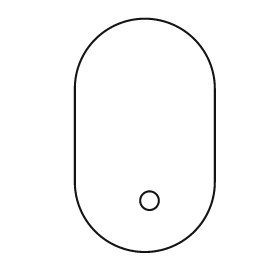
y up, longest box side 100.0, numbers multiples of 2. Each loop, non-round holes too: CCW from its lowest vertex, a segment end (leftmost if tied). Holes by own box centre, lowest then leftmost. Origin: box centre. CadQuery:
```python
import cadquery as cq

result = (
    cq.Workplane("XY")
    .moveTo(-30.0, -20.0)
    .threePointArc((0.0, -50.0), (30.0, -20.0))
    .lineTo(30.0, 20.0)
    .threePointArc((0.0, 50.0), (-30.0, 20.0))
    .close()
    .moveTo(2.0, -28.0)
    .circle(4.0)
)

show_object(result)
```